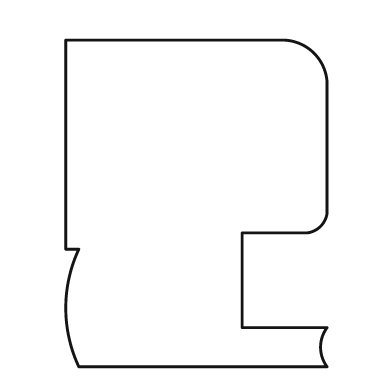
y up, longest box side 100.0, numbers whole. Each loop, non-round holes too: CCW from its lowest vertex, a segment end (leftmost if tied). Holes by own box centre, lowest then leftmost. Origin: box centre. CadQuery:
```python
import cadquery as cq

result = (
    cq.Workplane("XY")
    .moveTo(-36.0, -50.0)
    .lineTo(40.0, -50.0)
    .threePointArc((38.0, -44.0), (40.0, -38.0))
    .lineTo(14.0, -38.0)
    .lineTo(14.0, -9.0)
    .lineTo(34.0, -9.0)
    .threePointArc((38.0, -7.0), (40.0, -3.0))
    .lineTo(40.0, 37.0)
    .threePointArc((36.0, 46.0), (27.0, 50.0))
    .lineTo(-40.0, 50.0)
    .lineTo(-40.0, -14.0)
    .lineTo(-36.0, -14.0)
    .threePointArc((-40.0, -32.0), (-36.0, -50.0))
    .close()
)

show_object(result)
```